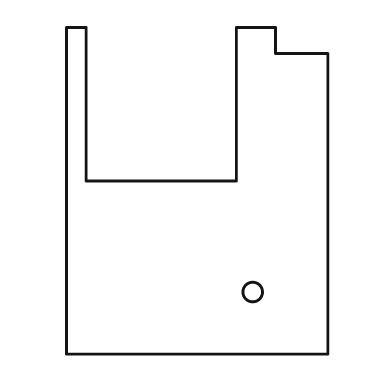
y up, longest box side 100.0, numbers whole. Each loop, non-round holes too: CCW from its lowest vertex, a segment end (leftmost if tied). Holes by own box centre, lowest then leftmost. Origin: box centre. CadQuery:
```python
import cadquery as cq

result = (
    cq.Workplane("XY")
    .moveTo(-40.0, -50.0)
    .lineTo(40.0, -50.0)
    .lineTo(40.0, 42.0)
    .lineTo(24.0, 42.0)
    .lineTo(24.0, 50.0)
    .lineTo(12.0, 50.0)
    .lineTo(12.0, 3.0)
    .lineTo(-34.0, 3.0)
    .lineTo(-34.0, 50.0)
    .lineTo(-40.0, 50.0)
    .close()
    .moveTo(17.0, -31.0)
    .circle(3.0)
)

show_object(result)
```